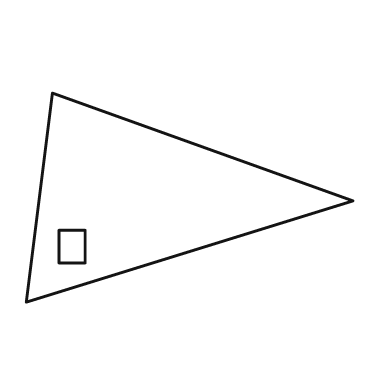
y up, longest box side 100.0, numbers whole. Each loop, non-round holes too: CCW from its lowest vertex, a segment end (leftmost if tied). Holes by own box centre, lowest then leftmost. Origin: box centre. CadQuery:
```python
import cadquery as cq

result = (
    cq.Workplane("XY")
    .moveTo(-50.0, -32.0)
    .lineTo(50.0, -1.0)
    .lineTo(-42.0, 32.0)
    .close()
    .moveTo(-40.0, -20.0)
    .lineTo(-32.0, -20.0)
    .lineTo(-32.0, -10.0)
    .lineTo(-40.0, -10.0)
    .close()
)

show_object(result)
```